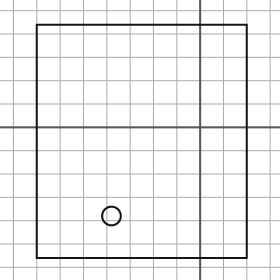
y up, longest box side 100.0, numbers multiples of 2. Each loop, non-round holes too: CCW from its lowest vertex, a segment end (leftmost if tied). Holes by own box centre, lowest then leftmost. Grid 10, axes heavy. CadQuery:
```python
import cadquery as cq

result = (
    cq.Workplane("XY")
    .moveTo(-70.0, -56.0)
    .lineTo(20.0, -56.0)
    .lineTo(20.0, 44.0)
    .lineTo(-70.0, 44.0)
    .close()
    .moveTo(-38.0, -38.0)
    .circle(4.0)
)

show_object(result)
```